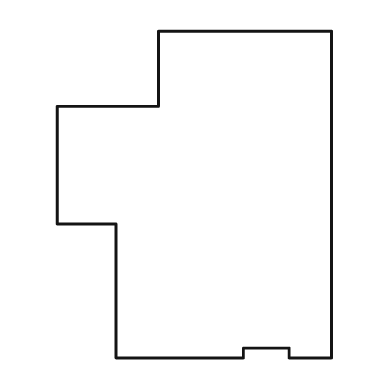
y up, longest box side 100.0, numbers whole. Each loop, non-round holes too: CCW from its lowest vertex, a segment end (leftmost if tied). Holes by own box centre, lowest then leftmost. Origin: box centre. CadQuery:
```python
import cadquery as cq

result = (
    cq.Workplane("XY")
    .moveTo(-24.0, -50.0)
    .lineTo(15.0, -50.0)
    .lineTo(15.0, -47.0)
    .lineTo(29.0, -47.0)
    .lineTo(29.0, -50.0)
    .lineTo(42.0, -50.0)
    .lineTo(42.0, 50.0)
    .lineTo(-11.0, 50.0)
    .lineTo(-11.0, 27.0)
    .lineTo(-42.0, 27.0)
    .lineTo(-42.0, -9.0)
    .lineTo(-24.0, -9.0)
    .close()
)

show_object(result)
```